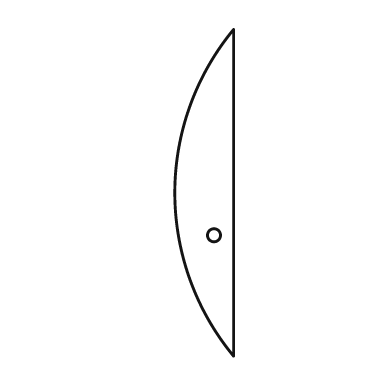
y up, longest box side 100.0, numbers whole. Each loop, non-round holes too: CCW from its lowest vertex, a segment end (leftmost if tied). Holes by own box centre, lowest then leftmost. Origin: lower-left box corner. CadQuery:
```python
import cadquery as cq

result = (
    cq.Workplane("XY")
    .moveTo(18.0, 0.0)
    .lineTo(18.0, 100.0)
    .threePointArc((0.0, 50.0), (18.0, 0.0))
    .close()
    .moveTo(12.0, 37.0)
    .circle(2.0)
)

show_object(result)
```